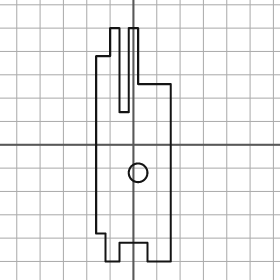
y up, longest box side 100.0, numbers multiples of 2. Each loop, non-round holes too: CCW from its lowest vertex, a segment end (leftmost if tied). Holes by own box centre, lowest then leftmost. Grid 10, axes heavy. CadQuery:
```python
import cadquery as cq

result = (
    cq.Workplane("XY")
    .moveTo(-12.0, -50.0)
    .lineTo(-6.0, -50.0)
    .lineTo(-6.0, -42.0)
    .lineTo(6.0, -42.0)
    .lineTo(6.0, -50.0)
    .lineTo(16.0, -50.0)
    .lineTo(16.0, 26.0)
    .lineTo(2.0, 26.0)
    .lineTo(2.0, 50.0)
    .lineTo(-2.0, 50.0)
    .lineTo(-2.0, 14.0)
    .lineTo(-6.0, 14.0)
    .lineTo(-6.0, 50.0)
    .lineTo(-10.0, 50.0)
    .lineTo(-10.0, 38.0)
    .lineTo(-16.0, 38.0)
    .lineTo(-16.0, -38.0)
    .lineTo(-12.0, -38.0)
    .close()
    .moveTo(2.0, -12.0)
    .circle(4.0)
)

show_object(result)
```